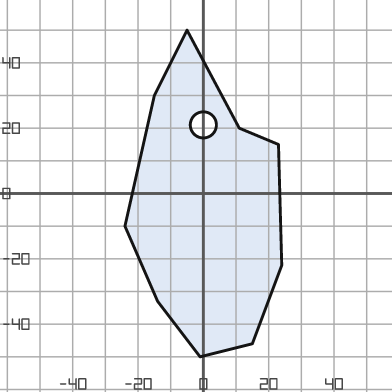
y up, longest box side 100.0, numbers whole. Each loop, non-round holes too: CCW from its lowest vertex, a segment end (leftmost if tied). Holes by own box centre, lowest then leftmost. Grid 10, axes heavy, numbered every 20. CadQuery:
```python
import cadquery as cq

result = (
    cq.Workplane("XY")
    .moveTo(-1.0, -50.0)
    .lineTo(15.0, -46.0)
    .lineTo(24.0, -22.0)
    .lineTo(23.0, 15.0)
    .lineTo(11.0, 20.0)
    .lineTo(-5.0, 50.0)
    .lineTo(-15.0, 30.0)
    .lineTo(-24.0, -10.0)
    .lineTo(-14.0, -33.0)
    .close()
    .moveTo(0.0, 21.0)
    .circle(4.0)
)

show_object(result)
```